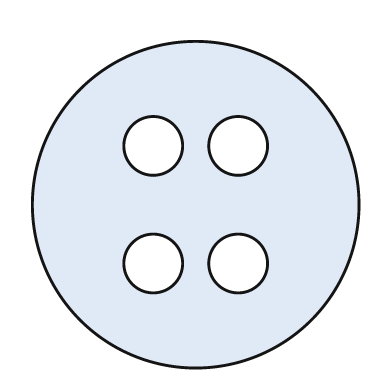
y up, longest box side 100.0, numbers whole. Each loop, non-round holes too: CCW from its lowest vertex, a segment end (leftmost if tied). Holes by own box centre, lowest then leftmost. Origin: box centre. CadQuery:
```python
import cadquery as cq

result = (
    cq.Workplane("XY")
    .moveTo(0.0, 0.0)
    .circle(50.0)
    .moveTo(-13.0, -18.0)
    .circle(9.0)
    .moveTo(13.0, -18.0)
    .circle(9.0)
    .moveTo(-13.0, 18.0)
    .circle(9.0)
    .moveTo(13.0, 18.0)
    .circle(9.0)
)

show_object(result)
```